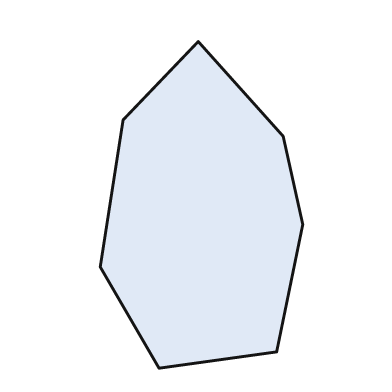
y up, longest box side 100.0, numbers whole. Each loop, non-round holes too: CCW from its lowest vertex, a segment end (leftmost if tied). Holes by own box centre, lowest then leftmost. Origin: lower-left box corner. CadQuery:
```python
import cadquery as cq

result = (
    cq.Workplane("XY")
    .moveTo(18.0, 0.0)
    .lineTo(54.0, 5.0)
    .lineTo(62.0, 44.0)
    .lineTo(56.0, 71.0)
    .lineTo(30.0, 100.0)
    .lineTo(7.0, 76.0)
    .lineTo(0.0, 31.0)
    .close()
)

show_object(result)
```